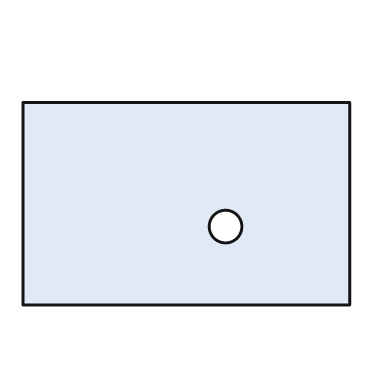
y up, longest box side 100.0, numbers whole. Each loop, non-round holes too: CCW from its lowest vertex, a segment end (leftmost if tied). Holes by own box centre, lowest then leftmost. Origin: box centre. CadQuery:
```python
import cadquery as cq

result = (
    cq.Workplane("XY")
    .moveTo(-50.0, -31.0)
    .lineTo(50.0, -31.0)
    .lineTo(50.0, 31.0)
    .lineTo(-50.0, 31.0)
    .close()
    .moveTo(12.0, -7.0)
    .circle(5.0)
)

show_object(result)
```